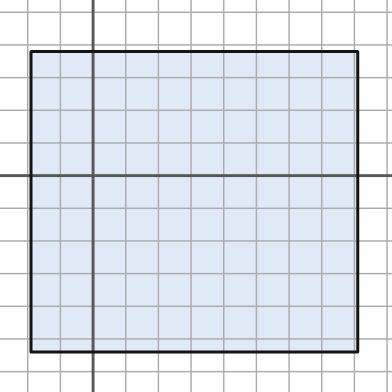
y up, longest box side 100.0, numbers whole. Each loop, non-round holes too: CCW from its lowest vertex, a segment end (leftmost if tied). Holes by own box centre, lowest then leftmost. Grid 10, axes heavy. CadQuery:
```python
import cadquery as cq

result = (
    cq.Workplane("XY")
    .moveTo(-19.0, -54.0)
    .lineTo(81.0, -54.0)
    .lineTo(81.0, 38.0)
    .lineTo(-19.0, 38.0)
    .close()
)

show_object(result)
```